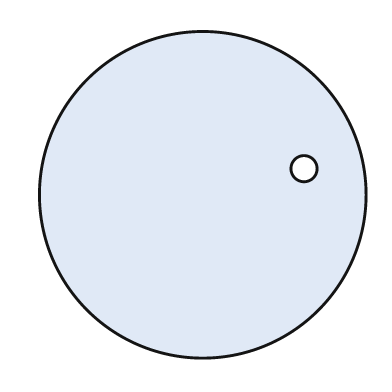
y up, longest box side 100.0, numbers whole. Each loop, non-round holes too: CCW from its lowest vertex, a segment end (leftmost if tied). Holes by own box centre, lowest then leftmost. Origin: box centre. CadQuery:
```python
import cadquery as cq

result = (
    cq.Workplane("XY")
    .moveTo(0.0, 0.0)
    .circle(50.0)
    .moveTo(31.0, 8.0)
    .circle(4.0)
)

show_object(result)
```